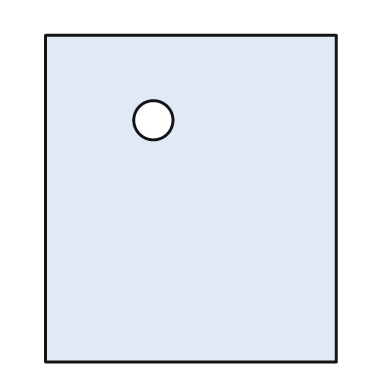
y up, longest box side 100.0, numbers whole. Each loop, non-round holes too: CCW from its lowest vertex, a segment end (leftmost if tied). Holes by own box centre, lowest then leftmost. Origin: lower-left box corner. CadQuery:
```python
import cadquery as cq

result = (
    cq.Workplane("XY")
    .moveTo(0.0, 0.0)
    .lineTo(89.0, 0.0)
    .lineTo(89.0, 100.0)
    .lineTo(0.0, 100.0)
    .close()
    .moveTo(33.0, 74.0)
    .circle(6.0)
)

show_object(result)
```